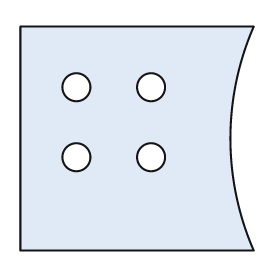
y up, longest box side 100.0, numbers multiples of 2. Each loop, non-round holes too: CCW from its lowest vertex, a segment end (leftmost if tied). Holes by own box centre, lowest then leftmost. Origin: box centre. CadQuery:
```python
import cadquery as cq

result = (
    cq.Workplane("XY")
    .moveTo(-50.0, -48.0)
    .lineTo(50.0, -48.0)
    .threePointArc((40.0, 0.0), (50.0, 48.0))
    .lineTo(-50.0, 48.0)
    .close()
    .moveTo(-26.0, -8.0)
    .circle(6.0)
    .moveTo(6.0, -8.0)
    .circle(6.0)
    .moveTo(-26.0, 22.0)
    .circle(6.0)
    .moveTo(6.0, 22.0)
    .circle(6.0)
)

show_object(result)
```